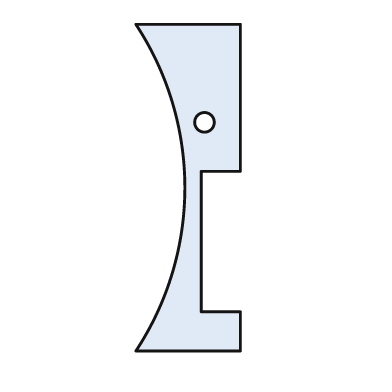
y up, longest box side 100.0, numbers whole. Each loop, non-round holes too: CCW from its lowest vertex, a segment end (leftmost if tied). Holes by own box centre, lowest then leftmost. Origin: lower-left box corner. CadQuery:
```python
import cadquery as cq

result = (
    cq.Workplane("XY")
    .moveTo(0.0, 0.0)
    .lineTo(32.0, 0.0)
    .lineTo(32.0, 12.0)
    .lineTo(20.0, 12.0)
    .lineTo(20.0, 55.0)
    .lineTo(32.0, 55.0)
    .lineTo(32.0, 100.0)
    .lineTo(0.0, 100.0)
    .threePointArc((15.0, 50.0), (0.0, 0.0))
    .close()
    .moveTo(21.0, 70.0)
    .circle(3.0)
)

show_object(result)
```